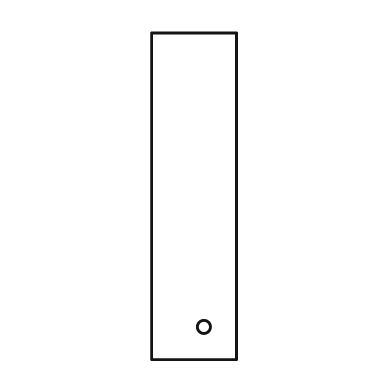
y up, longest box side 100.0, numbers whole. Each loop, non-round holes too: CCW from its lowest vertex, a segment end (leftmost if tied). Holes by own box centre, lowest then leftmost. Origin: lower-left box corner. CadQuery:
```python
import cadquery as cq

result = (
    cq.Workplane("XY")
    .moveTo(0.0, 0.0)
    .lineTo(26.0, 0.0)
    .lineTo(26.0, 100.0)
    .lineTo(0.0, 100.0)
    .close()
    .moveTo(16.0, 10.0)
    .circle(2.0)
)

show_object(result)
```